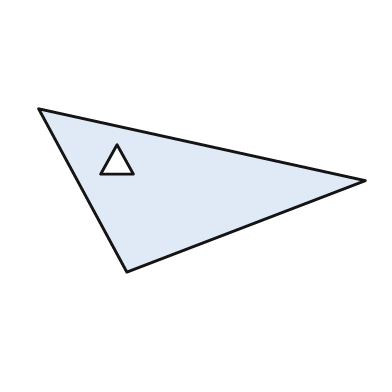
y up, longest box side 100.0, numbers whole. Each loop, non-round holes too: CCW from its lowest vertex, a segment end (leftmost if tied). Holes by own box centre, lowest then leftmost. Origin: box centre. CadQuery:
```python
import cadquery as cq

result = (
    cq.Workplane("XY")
    .moveTo(-23.0, -25.0)
    .lineTo(50.0, 3.0)
    .lineTo(-50.0, 25.0)
    .close()
    .moveTo(-31.0, 5.0)
    .lineTo(-21.0, 5.0)
    .lineTo(-26.0, 14.0)
    .close()
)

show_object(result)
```